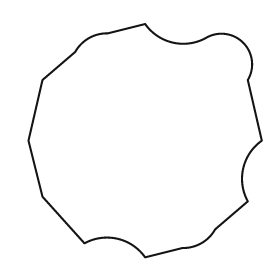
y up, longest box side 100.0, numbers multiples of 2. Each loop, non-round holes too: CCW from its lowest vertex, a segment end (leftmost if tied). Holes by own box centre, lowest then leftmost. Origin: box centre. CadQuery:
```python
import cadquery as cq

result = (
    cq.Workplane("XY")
    .moveTo(0.0, -50.0)
    .lineTo(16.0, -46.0)
    .threePointArc((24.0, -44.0), (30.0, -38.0))
    .lineTo(44.0, -26.0)
    .threePointArc((42.0, -12.0), (50.0, 0.0))
    .lineTo(44.0, 26.0)
    .threePointArc((42.0, 42.0), (26.0, 44.0))
    .threePointArc((12.0, 42.0), (0.0, 50.0))
    .lineTo(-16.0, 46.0)
    .threePointArc((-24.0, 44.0), (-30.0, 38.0))
    .lineTo(-44.0, 26.0)
    .lineTo(-50.0, 0.0)
    .lineTo(-44.0, -24.0)
    .lineTo(-26.0, -44.0)
    .threePointArc((-12.0, -42.0), (0.0, -50.0))
    .close()
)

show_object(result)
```